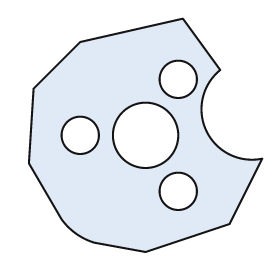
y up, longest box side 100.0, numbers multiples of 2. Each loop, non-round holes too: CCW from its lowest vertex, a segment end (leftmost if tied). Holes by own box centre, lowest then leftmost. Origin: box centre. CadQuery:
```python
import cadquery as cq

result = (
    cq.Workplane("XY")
    .moveTo(0.0, -50.0)
    .lineTo(36.0, -38.0)
    .lineTo(50.0, -10.0)
    .threePointArc((26.0, 2.0), (32.0, 28.0))
    .lineTo(16.0, 50.0)
    .lineTo(-28.0, 40.0)
    .lineTo(-48.0, 20.0)
    .lineTo(-50.0, -12.0)
    .lineTo(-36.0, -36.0)
    .threePointArc((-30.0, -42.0), (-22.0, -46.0))
    .close()
    .moveTo(14.0, -24.0)
    .circle(8.0)
    .moveTo(-28.0, 0.0)
    .circle(8.0)
    .moveTo(0.0, 0.0)
    .circle(14.0)
    .moveTo(14.0, 24.0)
    .circle(8.0)
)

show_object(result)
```